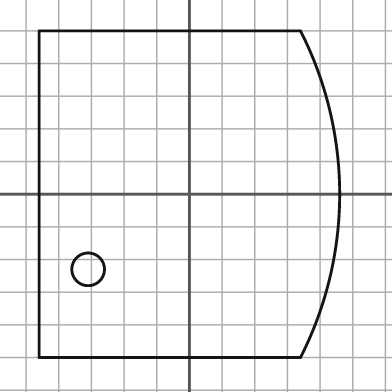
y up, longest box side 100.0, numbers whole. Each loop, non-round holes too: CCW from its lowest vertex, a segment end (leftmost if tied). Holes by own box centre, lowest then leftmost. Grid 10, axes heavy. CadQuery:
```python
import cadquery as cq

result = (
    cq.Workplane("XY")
    .moveTo(-46.0, -50.0)
    .lineTo(34.0, -50.0)
    .threePointArc((46.0, 0.0), (34.0, 50.0))
    .lineTo(-46.0, 50.0)
    .close()
    .moveTo(-31.0, -23.0)
    .circle(5.0)
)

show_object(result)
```